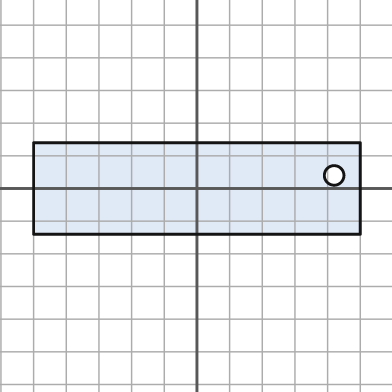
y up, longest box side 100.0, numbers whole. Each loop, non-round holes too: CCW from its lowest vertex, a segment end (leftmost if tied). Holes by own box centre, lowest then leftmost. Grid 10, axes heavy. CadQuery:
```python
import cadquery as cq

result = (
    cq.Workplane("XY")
    .moveTo(-50.0, -14.0)
    .lineTo(50.0, -14.0)
    .lineTo(50.0, 14.0)
    .lineTo(-50.0, 14.0)
    .close()
    .moveTo(42.0, 4.0)
    .circle(3.0)
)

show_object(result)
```